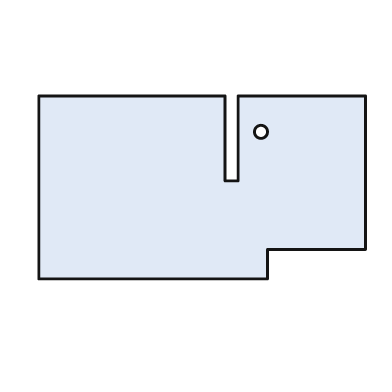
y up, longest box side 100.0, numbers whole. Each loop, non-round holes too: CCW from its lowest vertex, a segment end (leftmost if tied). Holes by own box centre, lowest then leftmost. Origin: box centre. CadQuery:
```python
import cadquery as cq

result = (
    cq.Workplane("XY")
    .moveTo(-50.0, -28.0)
    .lineTo(20.0, -28.0)
    .lineTo(20.0, -19.0)
    .lineTo(50.0, -19.0)
    .lineTo(50.0, 28.0)
    .lineTo(11.0, 28.0)
    .lineTo(11.0, 2.0)
    .lineTo(7.0, 2.0)
    .lineTo(7.0, 28.0)
    .lineTo(-50.0, 28.0)
    .close()
    .moveTo(18.0, 17.0)
    .circle(2.0)
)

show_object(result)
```